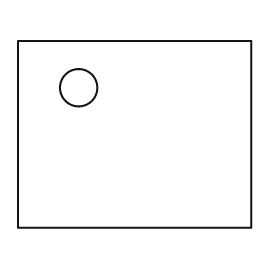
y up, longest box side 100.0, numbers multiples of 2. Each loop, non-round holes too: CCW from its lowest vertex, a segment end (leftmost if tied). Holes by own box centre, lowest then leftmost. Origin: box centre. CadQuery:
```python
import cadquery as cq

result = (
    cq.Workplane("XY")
    .moveTo(-50.0, -40.0)
    .lineTo(50.0, -40.0)
    .lineTo(50.0, 40.0)
    .lineTo(-50.0, 40.0)
    .close()
    .moveTo(-24.0, 20.0)
    .circle(8.0)
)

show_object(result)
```